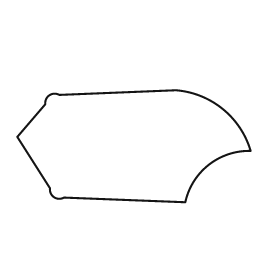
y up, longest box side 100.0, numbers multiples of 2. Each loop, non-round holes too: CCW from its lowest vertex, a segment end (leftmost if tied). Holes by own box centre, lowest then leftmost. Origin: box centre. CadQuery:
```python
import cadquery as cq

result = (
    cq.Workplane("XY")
    .moveTo(22.0, -24.0)
    .threePointArc((32.0, -8.0), (50.0, -2.0))
    .threePointArc((38.0, 16.0), (18.0, 24.0))
    .lineTo(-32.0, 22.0)
    .threePointArc((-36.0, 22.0), (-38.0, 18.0))
    .lineTo(-50.0, 4.0)
    .lineTo(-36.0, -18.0)
    .threePointArc((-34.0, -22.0), (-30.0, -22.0))
    .close()
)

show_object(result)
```